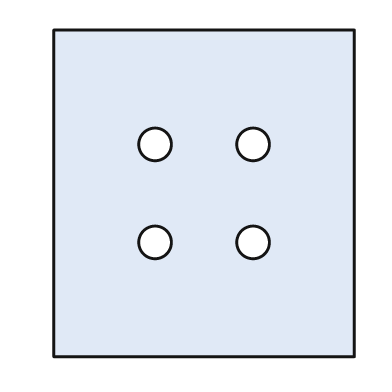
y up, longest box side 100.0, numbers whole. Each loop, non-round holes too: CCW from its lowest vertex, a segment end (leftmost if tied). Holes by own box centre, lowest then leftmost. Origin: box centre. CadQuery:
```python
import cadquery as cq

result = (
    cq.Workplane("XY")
    .moveTo(-46.0, -50.0)
    .lineTo(46.0, -50.0)
    .lineTo(46.0, 50.0)
    .lineTo(-46.0, 50.0)
    .close()
    .moveTo(-15.0, -15.0)
    .circle(5.0)
    .moveTo(15.0, -15.0)
    .circle(5.0)
    .moveTo(-15.0, 15.0)
    .circle(5.0)
    .moveTo(15.0, 15.0)
    .circle(5.0)
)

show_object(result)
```